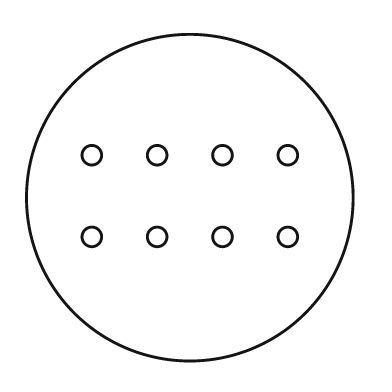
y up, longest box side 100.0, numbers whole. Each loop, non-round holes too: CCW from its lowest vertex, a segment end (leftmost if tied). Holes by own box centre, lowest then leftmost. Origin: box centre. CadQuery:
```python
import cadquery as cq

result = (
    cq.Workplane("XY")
    .moveTo(0.0, 0.0)
    .circle(50.0)
    .moveTo(-30.0, -12.0)
    .circle(3.0)
    .moveTo(-10.0, -12.0)
    .circle(3.0)
    .moveTo(10.0, -12.0)
    .circle(3.0)
    .moveTo(30.0, -12.0)
    .circle(3.0)
    .moveTo(-30.0, 13.0)
    .circle(3.0)
    .moveTo(-10.0, 13.0)
    .circle(3.0)
    .moveTo(10.0, 13.0)
    .circle(3.0)
    .moveTo(30.0, 13.0)
    .circle(3.0)
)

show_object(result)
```